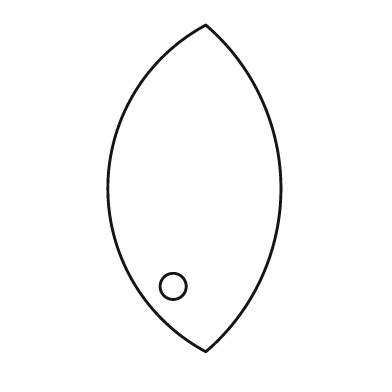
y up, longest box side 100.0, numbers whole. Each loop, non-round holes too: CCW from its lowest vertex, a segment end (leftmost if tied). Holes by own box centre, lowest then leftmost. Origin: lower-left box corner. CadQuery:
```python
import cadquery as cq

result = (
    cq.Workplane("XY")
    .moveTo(30.0, 0.0)
    .threePointArc((53.0, 50.0), (30.0, 100.0))
    .threePointArc((0.0, 50.0), (30.0, 0.0))
    .close()
    .moveTo(20.0, 20.0)
    .circle(4.0)
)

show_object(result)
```